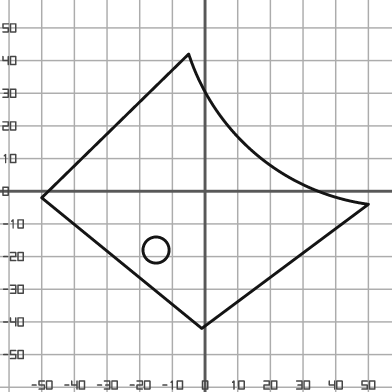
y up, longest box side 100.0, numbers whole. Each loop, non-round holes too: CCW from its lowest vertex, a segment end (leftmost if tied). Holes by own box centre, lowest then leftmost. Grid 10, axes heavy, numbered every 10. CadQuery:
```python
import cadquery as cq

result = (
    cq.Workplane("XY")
    .moveTo(-1.0, -42.0)
    .lineTo(50.0, -4.0)
    .threePointArc((16.0, 11.0), (-5.0, 42.0))
    .lineTo(-50.0, -2.0)
    .close()
    .moveTo(-15.0, -18.0)
    .circle(4.0)
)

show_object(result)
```